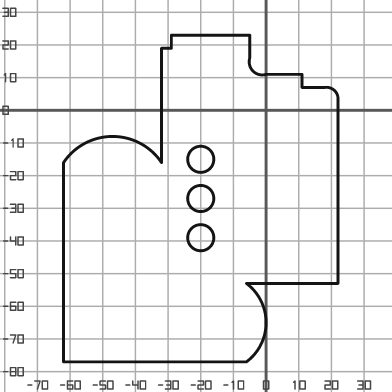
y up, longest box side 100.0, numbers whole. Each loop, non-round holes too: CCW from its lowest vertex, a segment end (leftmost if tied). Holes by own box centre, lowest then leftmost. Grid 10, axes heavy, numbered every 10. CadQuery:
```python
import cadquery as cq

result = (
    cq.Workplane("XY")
    .moveTo(-62.0, -77.0)
    .lineTo(-6.0, -77.0)
    .threePointArc((0.0, -65.0), (-6.0, -53.0))
    .lineTo(22.0, -53.0)
    .lineTo(22.0, 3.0)
    .threePointArc((21.0, 6.0), (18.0, 7.0))
    .lineTo(11.0, 7.0)
    .lineTo(11.0, 11.0)
    .lineTo(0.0, 11.0)
    .threePointArc((-4.0, 12.0), (-5.0, 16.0))
    .lineTo(-5.0, 23.0)
    .lineTo(-29.0, 23.0)
    .lineTo(-29.0, 19.0)
    .lineTo(-32.0, 19.0)
    .lineTo(-32.0, -16.0)
    .threePointArc((-47.0, -8.0), (-62.0, -16.0))
    .close()
    .moveTo(-20.0, -39.0)
    .circle(4.0)
    .moveTo(-20.0, -27.0)
    .circle(4.0)
    .moveTo(-20.0, -15.0)
    .circle(4.0)
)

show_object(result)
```